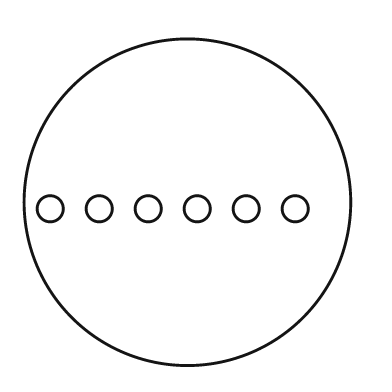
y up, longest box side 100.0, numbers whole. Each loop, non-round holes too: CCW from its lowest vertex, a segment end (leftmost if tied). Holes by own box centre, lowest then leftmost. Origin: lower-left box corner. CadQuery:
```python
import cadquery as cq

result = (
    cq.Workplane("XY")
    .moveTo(50.0, 50.0)
    .circle(50.0)
    .moveTo(8.0, 48.0)
    .circle(4.0)
    .moveTo(23.0, 48.0)
    .circle(4.0)
    .moveTo(38.0, 48.0)
    .circle(4.0)
    .moveTo(53.0, 48.0)
    .circle(4.0)
    .moveTo(68.0, 48.0)
    .circle(4.0)
    .moveTo(83.0, 48.0)
    .circle(4.0)
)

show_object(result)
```